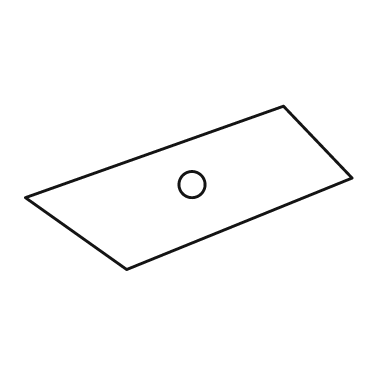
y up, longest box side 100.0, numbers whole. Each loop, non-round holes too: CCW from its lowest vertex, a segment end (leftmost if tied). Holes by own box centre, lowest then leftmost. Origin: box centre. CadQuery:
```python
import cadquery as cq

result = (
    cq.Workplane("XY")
    .moveTo(-19.0, -25.0)
    .lineTo(50.0, 3.0)
    .lineTo(29.0, 25.0)
    .lineTo(-50.0, -3.0)
    .close()
    .moveTo(1.0, 1.0)
    .circle(4.0)
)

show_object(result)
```